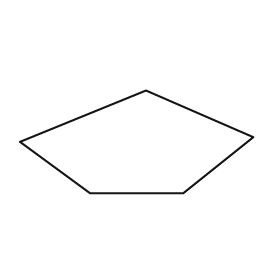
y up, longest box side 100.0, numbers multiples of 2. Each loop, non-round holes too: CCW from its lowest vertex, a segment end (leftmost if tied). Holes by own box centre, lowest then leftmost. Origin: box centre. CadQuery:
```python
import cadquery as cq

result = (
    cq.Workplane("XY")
    .moveTo(-20.0, -22.0)
    .lineTo(20.0, -22.0)
    .lineTo(50.0, 2.0)
    .lineTo(4.0, 22.0)
    .lineTo(-50.0, 0.0)
    .close()
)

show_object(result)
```